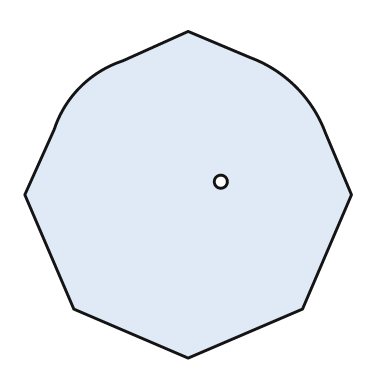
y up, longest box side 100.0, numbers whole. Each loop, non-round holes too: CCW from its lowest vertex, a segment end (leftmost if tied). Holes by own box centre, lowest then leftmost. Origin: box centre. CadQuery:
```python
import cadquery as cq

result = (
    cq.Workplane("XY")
    .moveTo(0.0, -50.0)
    .lineTo(35.0, -35.0)
    .lineTo(50.0, 0.0)
    .lineTo(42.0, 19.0)
    .threePointArc((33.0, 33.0), (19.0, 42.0))
    .lineTo(0.0, 50.0)
    .lineTo(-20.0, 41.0)
    .threePointArc((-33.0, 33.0), (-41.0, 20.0))
    .lineTo(-50.0, 0.0)
    .lineTo(-35.0, -35.0)
    .close()
    .moveTo(10.0, 4.0)
    .circle(2.0)
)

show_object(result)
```